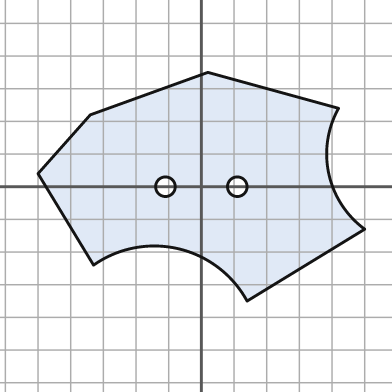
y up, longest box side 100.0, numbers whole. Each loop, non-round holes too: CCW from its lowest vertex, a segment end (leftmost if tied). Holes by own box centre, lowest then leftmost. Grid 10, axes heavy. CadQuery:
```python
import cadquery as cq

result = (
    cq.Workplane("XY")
    .moveTo(14.0, -35.0)
    .lineTo(50.0, -13.0)
    .threePointArc((39.0, 4.0), (42.0, 24.0))
    .lineTo(2.0, 35.0)
    .lineTo(-34.0, 22.0)
    .lineTo(-50.0, 4.0)
    .lineTo(-33.0, -24.0)
    .threePointArc((-7.0, -19.0), (14.0, -35.0))
    .close()
    .moveTo(-11.0, 0.0)
    .circle(3.0)
    .moveTo(11.0, 0.0)
    .circle(3.0)
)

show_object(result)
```